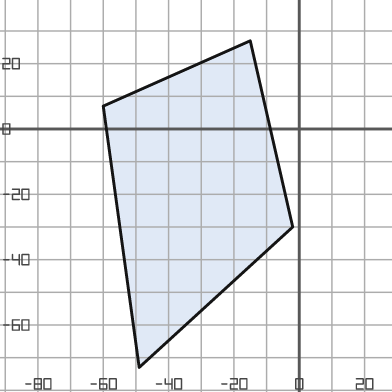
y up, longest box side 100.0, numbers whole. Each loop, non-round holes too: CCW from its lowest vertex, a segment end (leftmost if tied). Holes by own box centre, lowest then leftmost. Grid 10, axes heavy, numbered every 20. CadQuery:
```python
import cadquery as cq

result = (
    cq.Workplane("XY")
    .moveTo(-49.0, -73.0)
    .lineTo(-2.0, -30.0)
    .lineTo(-15.0, 27.0)
    .lineTo(-60.0, 7.0)
    .close()
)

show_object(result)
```